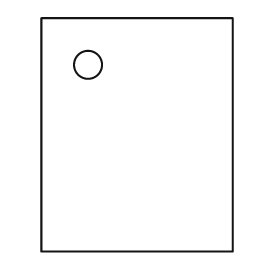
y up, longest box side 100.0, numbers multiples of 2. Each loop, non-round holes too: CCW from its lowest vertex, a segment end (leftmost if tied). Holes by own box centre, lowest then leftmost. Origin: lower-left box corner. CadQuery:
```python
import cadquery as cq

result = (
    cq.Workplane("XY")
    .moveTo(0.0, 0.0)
    .lineTo(82.0, 0.0)
    .lineTo(82.0, 100.0)
    .lineTo(0.0, 100.0)
    .close()
    .moveTo(20.0, 80.0)
    .circle(6.0)
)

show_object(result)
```